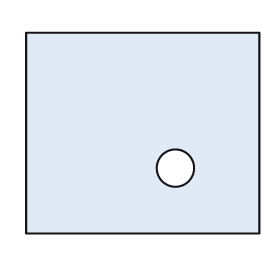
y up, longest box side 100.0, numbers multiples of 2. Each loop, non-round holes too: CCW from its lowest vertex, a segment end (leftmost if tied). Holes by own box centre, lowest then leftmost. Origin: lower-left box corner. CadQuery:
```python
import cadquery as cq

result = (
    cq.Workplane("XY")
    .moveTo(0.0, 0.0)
    .lineTo(100.0, 0.0)
    .lineTo(100.0, 86.0)
    .lineTo(0.0, 86.0)
    .close()
    .moveTo(64.0, 28.0)
    .circle(8.0)
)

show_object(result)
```